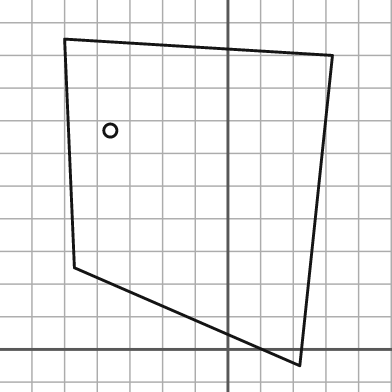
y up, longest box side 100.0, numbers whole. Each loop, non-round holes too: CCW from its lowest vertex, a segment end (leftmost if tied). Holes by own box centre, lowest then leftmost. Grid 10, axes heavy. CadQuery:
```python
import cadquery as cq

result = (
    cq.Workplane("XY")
    .moveTo(22.0, -5.0)
    .lineTo(32.0, 90.0)
    .lineTo(-50.0, 95.0)
    .lineTo(-47.0, 25.0)
    .close()
    .moveTo(-36.0, 67.0)
    .circle(2.0)
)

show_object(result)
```